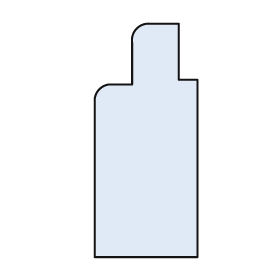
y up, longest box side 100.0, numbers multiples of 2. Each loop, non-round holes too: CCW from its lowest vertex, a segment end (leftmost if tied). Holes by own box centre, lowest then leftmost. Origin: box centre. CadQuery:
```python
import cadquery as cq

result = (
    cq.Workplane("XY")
    .moveTo(-22.0, -50.0)
    .lineTo(22.0, -50.0)
    .lineTo(22.0, 26.0)
    .lineTo(14.0, 26.0)
    .lineTo(14.0, 50.0)
    .lineTo(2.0, 50.0)
    .threePointArc((-4.0, 48.0), (-6.0, 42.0))
    .lineTo(-6.0, 24.0)
    .lineTo(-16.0, 24.0)
    .threePointArc((-20.0, 22.0), (-22.0, 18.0))
    .close()
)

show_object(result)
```